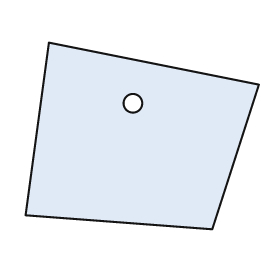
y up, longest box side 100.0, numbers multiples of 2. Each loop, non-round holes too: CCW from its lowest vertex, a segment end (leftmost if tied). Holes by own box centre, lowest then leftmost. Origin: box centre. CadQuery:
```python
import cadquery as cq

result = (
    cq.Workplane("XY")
    .moveTo(30.0, -40.0)
    .lineTo(50.0, 22.0)
    .lineTo(-40.0, 40.0)
    .lineTo(-50.0, -34.0)
    .close()
    .moveTo(-4.0, 14.0)
    .circle(4.0)
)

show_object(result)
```